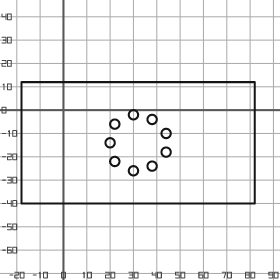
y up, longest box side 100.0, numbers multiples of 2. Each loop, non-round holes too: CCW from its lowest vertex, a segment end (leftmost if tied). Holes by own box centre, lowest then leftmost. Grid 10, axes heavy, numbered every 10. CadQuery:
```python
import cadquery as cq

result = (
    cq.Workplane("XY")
    .moveTo(-18.0, -40.0)
    .lineTo(82.0, -40.0)
    .lineTo(82.0, 12.0)
    .lineTo(-18.0, 12.0)
    .close()
    .moveTo(30.0, -26.0)
    .circle(2.0)
    .moveTo(38.0, -24.0)
    .circle(2.0)
    .moveTo(22.0, -22.0)
    .circle(2.0)
    .moveTo(44.0, -18.0)
    .circle(2.0)
    .moveTo(20.0, -14.0)
    .circle(2.0)
    .moveTo(44.0, -10.0)
    .circle(2.0)
    .moveTo(22.0, -6.0)
    .circle(2.0)
    .moveTo(38.0, -4.0)
    .circle(2.0)
    .moveTo(30.0, -2.0)
    .circle(2.0)
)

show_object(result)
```